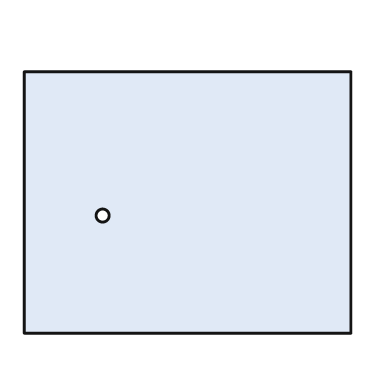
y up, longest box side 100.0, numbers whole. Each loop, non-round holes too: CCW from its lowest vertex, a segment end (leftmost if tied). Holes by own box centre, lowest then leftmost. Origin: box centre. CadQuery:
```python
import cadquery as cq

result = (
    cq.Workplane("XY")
    .moveTo(-50.0, -40.0)
    .lineTo(50.0, -40.0)
    .lineTo(50.0, 40.0)
    .lineTo(-50.0, 40.0)
    .close()
    .moveTo(-26.0, -4.0)
    .circle(2.0)
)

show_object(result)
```